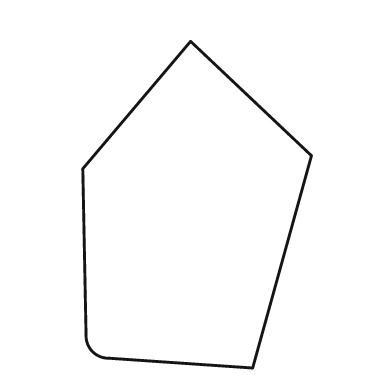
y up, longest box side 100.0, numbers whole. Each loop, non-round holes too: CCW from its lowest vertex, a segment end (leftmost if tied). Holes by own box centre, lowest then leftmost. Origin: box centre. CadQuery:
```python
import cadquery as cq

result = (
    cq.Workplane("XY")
    .moveTo(17.0, -50.0)
    .lineTo(35.0, 15.0)
    .lineTo(-2.0, 50.0)
    .lineTo(-35.0, 11.0)
    .lineTo(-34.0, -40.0)
    .threePointArc((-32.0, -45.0), (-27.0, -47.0))
    .close()
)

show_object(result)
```